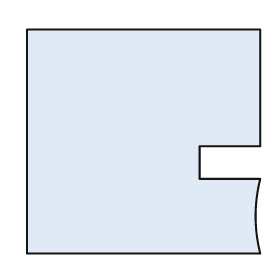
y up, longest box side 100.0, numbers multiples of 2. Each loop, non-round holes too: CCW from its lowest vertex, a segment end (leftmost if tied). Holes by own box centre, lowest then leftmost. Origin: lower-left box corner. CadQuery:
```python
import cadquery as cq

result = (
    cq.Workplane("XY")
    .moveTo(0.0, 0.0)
    .lineTo(100.0, 0.0)
    .threePointArc((98.0, 16.0), (100.0, 32.0))
    .lineTo(74.0, 32.0)
    .lineTo(74.0, 46.0)
    .lineTo(100.0, 46.0)
    .lineTo(100.0, 96.0)
    .lineTo(0.0, 96.0)
    .close()
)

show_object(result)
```